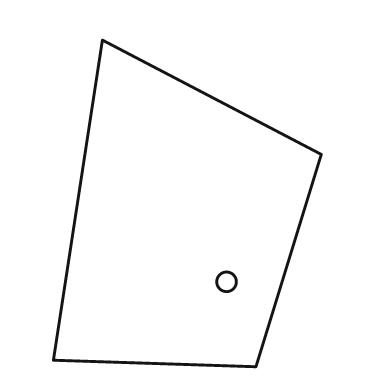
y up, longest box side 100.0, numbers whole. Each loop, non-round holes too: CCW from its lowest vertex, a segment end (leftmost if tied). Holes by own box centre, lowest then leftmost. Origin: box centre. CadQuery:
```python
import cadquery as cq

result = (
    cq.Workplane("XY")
    .moveTo(21.0, -50.0)
    .lineTo(41.0, 15.0)
    .lineTo(-26.0, 50.0)
    .lineTo(-41.0, -48.0)
    .close()
    .moveTo(12.0, -24.0)
    .circle(3.0)
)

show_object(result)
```